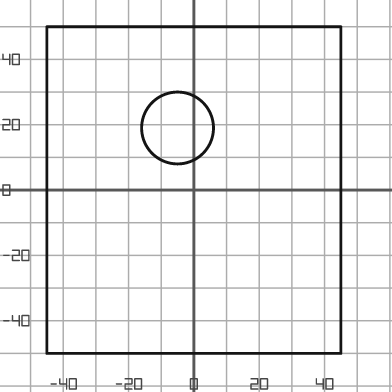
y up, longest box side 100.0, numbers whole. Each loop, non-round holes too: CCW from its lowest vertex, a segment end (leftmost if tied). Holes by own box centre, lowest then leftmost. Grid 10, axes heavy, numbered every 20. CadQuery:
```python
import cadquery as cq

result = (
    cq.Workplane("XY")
    .moveTo(-45.0, -50.0)
    .lineTo(45.0, -50.0)
    .lineTo(45.0, 50.0)
    .lineTo(-45.0, 50.0)
    .close()
    .moveTo(-5.0, 19.0)
    .circle(11.0)
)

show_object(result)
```